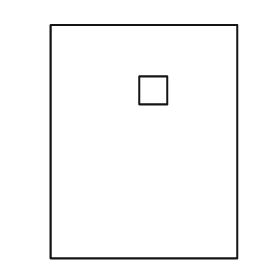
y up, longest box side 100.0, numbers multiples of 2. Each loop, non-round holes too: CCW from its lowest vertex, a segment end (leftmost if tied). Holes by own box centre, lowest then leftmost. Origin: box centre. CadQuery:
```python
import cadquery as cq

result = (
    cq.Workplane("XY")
    .moveTo(-40.0, -50.0)
    .lineTo(40.0, -50.0)
    .lineTo(40.0, 50.0)
    .lineTo(-40.0, 50.0)
    .close()
    .moveTo(-2.0, 16.0)
    .lineTo(10.0, 16.0)
    .lineTo(10.0, 28.0)
    .lineTo(-2.0, 28.0)
    .close()
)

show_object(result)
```